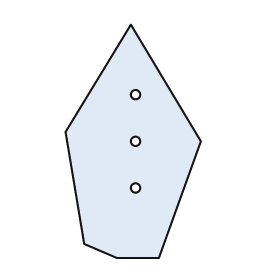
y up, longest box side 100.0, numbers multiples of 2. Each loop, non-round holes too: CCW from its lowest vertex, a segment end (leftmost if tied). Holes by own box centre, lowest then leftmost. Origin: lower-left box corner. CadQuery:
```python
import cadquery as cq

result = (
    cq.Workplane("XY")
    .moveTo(22.0, 0.0)
    .lineTo(40.0, 0.0)
    .lineTo(58.0, 50.0)
    .lineTo(28.0, 100.0)
    .lineTo(0.0, 54.0)
    .lineTo(8.0, 6.0)
    .close()
    .moveTo(30.0, 30.0)
    .circle(2.0)
    .moveTo(30.0, 50.0)
    .circle(2.0)
    .moveTo(30.0, 70.0)
    .circle(2.0)
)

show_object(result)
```